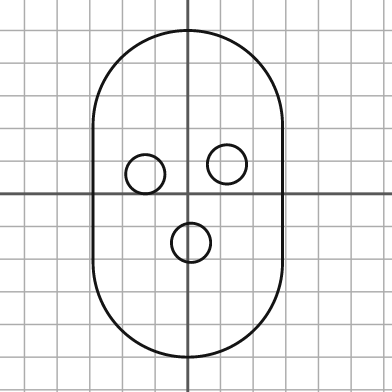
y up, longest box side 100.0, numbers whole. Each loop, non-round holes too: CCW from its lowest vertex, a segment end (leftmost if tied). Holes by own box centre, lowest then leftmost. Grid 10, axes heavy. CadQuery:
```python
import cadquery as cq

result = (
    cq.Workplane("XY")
    .moveTo(-29.0, -21.0)
    .threePointArc((0.0, -50.0), (29.0, -21.0))
    .lineTo(29.0, 21.0)
    .threePointArc((0.0, 50.0), (-29.0, 21.0))
    .close()
    .moveTo(1.0, -15.0)
    .circle(6.0)
    .moveTo(-13.0, 6.0)
    .circle(6.0)
    .moveTo(12.0, 9.0)
    .circle(6.0)
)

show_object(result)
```